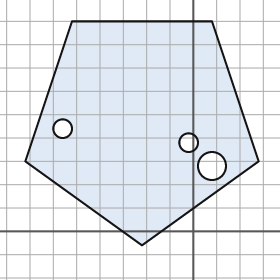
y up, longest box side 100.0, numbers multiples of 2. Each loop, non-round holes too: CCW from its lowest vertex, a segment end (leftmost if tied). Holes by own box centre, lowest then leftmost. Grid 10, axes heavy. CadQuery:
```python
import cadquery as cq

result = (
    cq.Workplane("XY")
    .moveTo(-22.0, -6.0)
    .lineTo(28.0, 30.0)
    .lineTo(8.0, 90.0)
    .lineTo(-52.0, 90.0)
    .lineTo(-72.0, 30.0)
    .close()
    .moveTo(8.0, 28.0)
    .circle(6.0)
    .moveTo(-2.0, 38.0)
    .circle(4.0)
    .moveTo(-56.0, 44.0)
    .circle(4.0)
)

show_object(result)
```